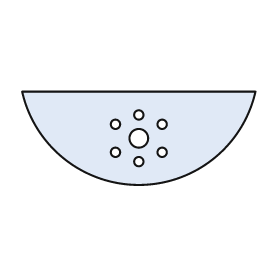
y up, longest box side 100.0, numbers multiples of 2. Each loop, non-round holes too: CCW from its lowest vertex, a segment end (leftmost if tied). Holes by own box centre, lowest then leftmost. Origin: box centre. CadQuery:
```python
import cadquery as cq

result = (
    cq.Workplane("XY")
    .moveTo(-50.0, 20.0)
    .threePointArc((0.0, -20.0), (50.0, 20.0))
    .close()
    .moveTo(0.0, -10.0)
    .circle(2.0)
    .moveTo(-10.0, -6.0)
    .circle(2.0)
    .moveTo(10.0, -6.0)
    .circle(2.0)
    .moveTo(0.0, 0.0)
    .circle(4.0)
    .moveTo(-10.0, 6.0)
    .circle(2.0)
    .moveTo(10.0, 6.0)
    .circle(2.0)
    .moveTo(0.0, 10.0)
    .circle(2.0)
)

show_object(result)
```